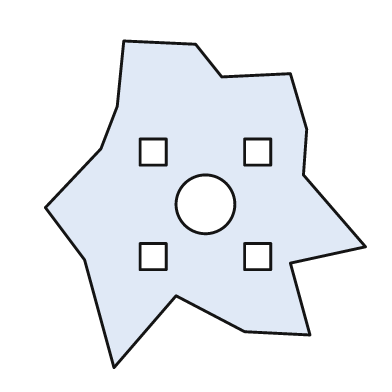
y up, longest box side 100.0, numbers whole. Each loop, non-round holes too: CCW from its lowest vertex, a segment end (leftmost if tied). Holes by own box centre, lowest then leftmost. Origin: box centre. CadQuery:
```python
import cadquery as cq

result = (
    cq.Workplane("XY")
    .moveTo(-28.0, -50.0)
    .lineTo(-9.0, -28.0)
    .lineTo(12.0, -39.0)
    .lineTo(32.0, -40.0)
    .lineTo(26.0, -18.0)
    .lineTo(49.0, -13.0)
    .lineTo(30.0, 9.0)
    .lineTo(31.0, 23.0)
    .lineTo(26.0, 40.0)
    .lineTo(5.0, 39.0)
    .lineTo(-3.0, 49.0)
    .lineTo(-25.0, 50.0)
    .lineTo(-27.0, 30.0)
    .lineTo(-32.0, 17.0)
    .lineTo(-49.0, -1.0)
    .lineTo(-37.0, -17.0)
    .close()
    .moveTo(-20.0, -20.0)
    .lineTo(-12.0, -20.0)
    .lineTo(-12.0, -12.0)
    .lineTo(-20.0, -12.0)
    .close()
    .moveTo(12.0, -20.0)
    .lineTo(20.0, -20.0)
    .lineTo(20.0, -12.0)
    .lineTo(12.0, -12.0)
    .close()
    .moveTo(0.0, 0.0)
    .circle(9.0)
    .moveTo(-20.0, 12.0)
    .lineTo(-12.0, 12.0)
    .lineTo(-12.0, 20.0)
    .lineTo(-20.0, 20.0)
    .close()
    .moveTo(12.0, 12.0)
    .lineTo(20.0, 12.0)
    .lineTo(20.0, 20.0)
    .lineTo(12.0, 20.0)
    .close()
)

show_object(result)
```